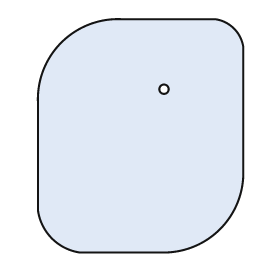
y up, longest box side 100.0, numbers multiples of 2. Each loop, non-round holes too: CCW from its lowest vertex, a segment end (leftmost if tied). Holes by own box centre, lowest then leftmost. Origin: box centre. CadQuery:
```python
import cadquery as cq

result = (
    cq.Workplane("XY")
    .moveTo(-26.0, -50.0)
    .lineTo(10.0, -50.0)
    .threePointArc((34.0, -40.0), (44.0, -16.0))
    .lineTo(44.0, 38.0)
    .threePointArc((40.0, 46.0), (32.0, 50.0))
    .lineTo(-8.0, 50.0)
    .threePointArc((-34.0, 40.0), (-44.0, 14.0))
    .lineTo(-44.0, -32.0)
    .threePointArc((-38.0, -44.0), (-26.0, -50.0))
    .close()
    .moveTo(10.0, 20.0)
    .circle(2.0)
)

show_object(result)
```